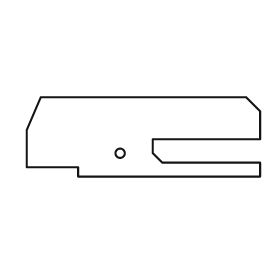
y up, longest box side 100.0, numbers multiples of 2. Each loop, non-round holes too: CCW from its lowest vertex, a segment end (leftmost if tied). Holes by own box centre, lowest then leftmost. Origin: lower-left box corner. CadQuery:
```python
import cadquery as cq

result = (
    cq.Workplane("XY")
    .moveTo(22.0, 0.0)
    .lineTo(100.0, 0.0)
    .lineTo(100.0, 6.0)
    .lineTo(58.0, 6.0)
    .lineTo(54.0, 10.0)
    .lineTo(54.0, 16.0)
    .lineTo(100.0, 16.0)
    .lineTo(100.0, 28.0)
    .lineTo(94.0, 34.0)
    .lineTo(6.0, 34.0)
    .lineTo(0.0, 20.0)
    .lineTo(0.0, 4.0)
    .lineTo(22.0, 4.0)
    .close()
    .moveTo(40.0, 10.0)
    .circle(2.0)
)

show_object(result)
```